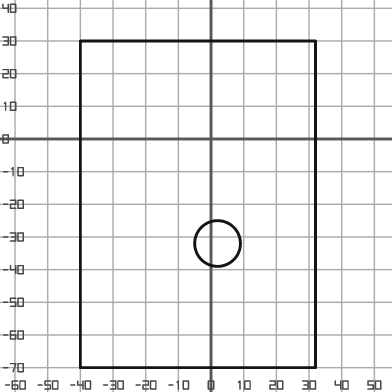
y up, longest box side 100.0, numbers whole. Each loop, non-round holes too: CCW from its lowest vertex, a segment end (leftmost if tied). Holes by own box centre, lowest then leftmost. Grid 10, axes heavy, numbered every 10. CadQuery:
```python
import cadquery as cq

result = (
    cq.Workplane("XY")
    .moveTo(-40.0, -70.0)
    .lineTo(32.0, -70.0)
    .lineTo(32.0, 30.0)
    .lineTo(-40.0, 30.0)
    .close()
    .moveTo(2.0, -32.0)
    .circle(7.0)
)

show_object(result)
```